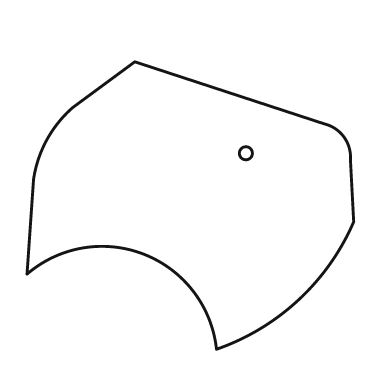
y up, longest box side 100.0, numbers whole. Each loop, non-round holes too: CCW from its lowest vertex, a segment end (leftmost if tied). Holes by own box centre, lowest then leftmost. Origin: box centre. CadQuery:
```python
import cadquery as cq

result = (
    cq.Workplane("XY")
    .moveTo(8.0, -44.0)
    .threePointArc((33.0, -29.0), (50.0, -5.0))
    .lineTo(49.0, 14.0)
    .threePointArc((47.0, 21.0), (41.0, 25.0))
    .lineTo(-17.0, 44.0)
    .lineTo(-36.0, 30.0)
    .threePointArc((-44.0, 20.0), (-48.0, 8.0))
    .lineTo(-50.0, -21.0)
    .threePointArc((-14.0, -15.0), (8.0, -44.0))
    .close()
    .moveTo(17.0, 16.0)
    .circle(2.0)
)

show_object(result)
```